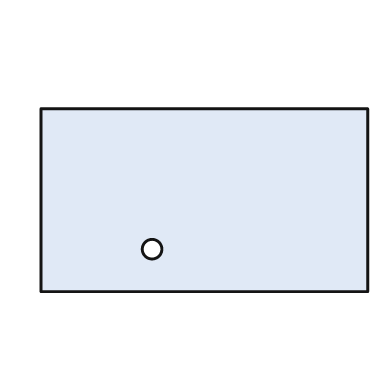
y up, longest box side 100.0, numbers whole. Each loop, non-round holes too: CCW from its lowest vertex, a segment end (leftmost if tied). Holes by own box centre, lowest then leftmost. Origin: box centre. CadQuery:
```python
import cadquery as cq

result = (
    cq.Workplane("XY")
    .moveTo(-50.0, -28.0)
    .lineTo(50.0, -28.0)
    .lineTo(50.0, 28.0)
    .lineTo(-50.0, 28.0)
    .close()
    .moveTo(-16.0, -15.0)
    .circle(3.0)
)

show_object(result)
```